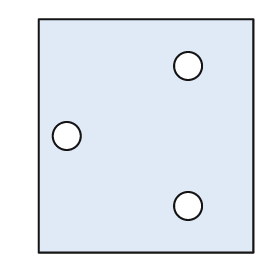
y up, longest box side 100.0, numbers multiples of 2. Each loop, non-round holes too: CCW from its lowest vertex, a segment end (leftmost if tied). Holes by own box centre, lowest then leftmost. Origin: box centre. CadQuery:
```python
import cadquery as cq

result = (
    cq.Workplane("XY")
    .moveTo(-46.0, -50.0)
    .lineTo(46.0, -50.0)
    .lineTo(46.0, 50.0)
    .lineTo(-46.0, 50.0)
    .close()
    .moveTo(18.0, -30.0)
    .circle(6.0)
    .moveTo(-34.0, 0.0)
    .circle(6.0)
    .moveTo(18.0, 30.0)
    .circle(6.0)
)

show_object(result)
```